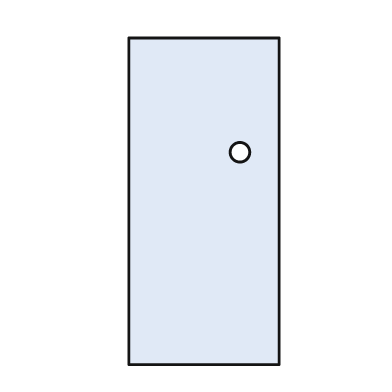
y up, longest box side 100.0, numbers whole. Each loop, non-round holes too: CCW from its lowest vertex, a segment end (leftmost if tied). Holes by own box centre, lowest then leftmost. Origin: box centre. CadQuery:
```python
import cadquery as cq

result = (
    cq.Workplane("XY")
    .moveTo(-23.0, -50.0)
    .lineTo(23.0, -50.0)
    .lineTo(23.0, 50.0)
    .lineTo(-23.0, 50.0)
    .close()
    .moveTo(11.0, 15.0)
    .circle(3.0)
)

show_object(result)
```